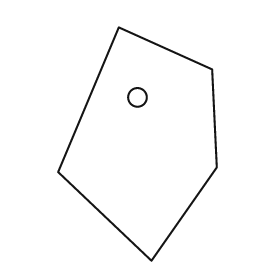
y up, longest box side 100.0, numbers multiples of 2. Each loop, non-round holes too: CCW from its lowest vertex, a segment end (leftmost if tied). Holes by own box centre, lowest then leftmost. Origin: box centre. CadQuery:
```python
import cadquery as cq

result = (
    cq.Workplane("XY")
    .moveTo(6.0, -50.0)
    .lineTo(34.0, -10.0)
    .lineTo(32.0, 32.0)
    .lineTo(-8.0, 50.0)
    .lineTo(-34.0, -12.0)
    .close()
    .moveTo(0.0, 20.0)
    .circle(4.0)
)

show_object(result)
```